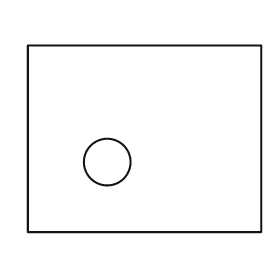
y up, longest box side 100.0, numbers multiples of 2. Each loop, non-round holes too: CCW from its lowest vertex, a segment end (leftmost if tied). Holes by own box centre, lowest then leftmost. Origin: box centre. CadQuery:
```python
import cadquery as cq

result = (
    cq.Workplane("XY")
    .moveTo(-50.0, -40.0)
    .lineTo(50.0, -40.0)
    .lineTo(50.0, 40.0)
    .lineTo(-50.0, 40.0)
    .close()
    .moveTo(-16.0, -10.0)
    .circle(10.0)
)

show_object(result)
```